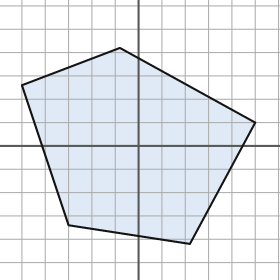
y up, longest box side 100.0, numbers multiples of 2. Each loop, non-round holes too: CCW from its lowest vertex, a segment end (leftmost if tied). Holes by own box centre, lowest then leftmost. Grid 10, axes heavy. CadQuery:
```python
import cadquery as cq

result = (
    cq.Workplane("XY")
    .moveTo(22.0, -42.0)
    .lineTo(50.0, 10.0)
    .lineTo(-8.0, 42.0)
    .lineTo(-50.0, 26.0)
    .lineTo(-30.0, -34.0)
    .close()
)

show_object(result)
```